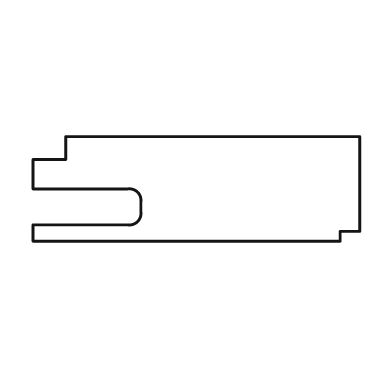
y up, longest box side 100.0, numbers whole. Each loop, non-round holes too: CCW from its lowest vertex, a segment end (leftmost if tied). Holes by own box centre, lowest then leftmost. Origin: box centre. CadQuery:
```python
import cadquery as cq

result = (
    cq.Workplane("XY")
    .moveTo(-50.0, -16.0)
    .lineTo(44.0, -16.0)
    .lineTo(44.0, -13.0)
    .lineTo(50.0, -13.0)
    .lineTo(50.0, 16.0)
    .lineTo(-40.0, 16.0)
    .lineTo(-40.0, 9.0)
    .lineTo(-50.0, 9.0)
    .lineTo(-50.0, 0.0)
    .lineTo(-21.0, 0.0)
    .threePointArc((-18.0, -1.0), (-17.0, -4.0))
    .lineTo(-17.0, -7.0)
    .threePointArc((-18.0, -10.0), (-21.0, -11.0))
    .lineTo(-50.0, -11.0)
    .close()
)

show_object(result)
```